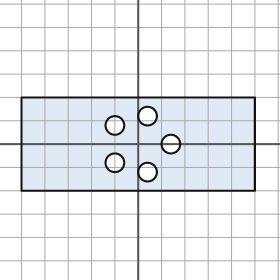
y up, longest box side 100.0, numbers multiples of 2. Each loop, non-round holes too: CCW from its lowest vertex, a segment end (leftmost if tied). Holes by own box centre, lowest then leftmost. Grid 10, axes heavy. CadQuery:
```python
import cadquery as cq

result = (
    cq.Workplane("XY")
    .moveTo(-50.0, -20.0)
    .lineTo(50.0, -20.0)
    .lineTo(50.0, 20.0)
    .lineTo(-50.0, 20.0)
    .close()
    .moveTo(4.0, -12.0)
    .circle(4.0)
    .moveTo(-10.0, -8.0)
    .circle(4.0)
    .moveTo(14.0, 0.0)
    .circle(4.0)
    .moveTo(-10.0, 8.0)
    .circle(4.0)
    .moveTo(4.0, 12.0)
    .circle(4.0)
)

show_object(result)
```